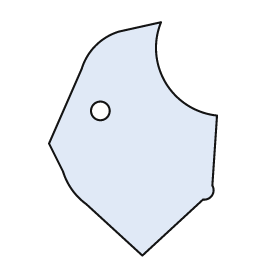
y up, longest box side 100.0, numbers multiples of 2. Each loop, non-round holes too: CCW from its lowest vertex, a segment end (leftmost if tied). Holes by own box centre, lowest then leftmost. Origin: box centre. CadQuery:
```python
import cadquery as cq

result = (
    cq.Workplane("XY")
    .moveTo(4.0, -50.0)
    .lineTo(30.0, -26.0)
    .threePointArc((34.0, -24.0), (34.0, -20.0))
    .lineTo(36.0, 10.0)
    .threePointArc((14.0, 24.0), (12.0, 50.0))
    .lineTo(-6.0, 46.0)
    .threePointArc((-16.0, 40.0), (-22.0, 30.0))
    .lineTo(-36.0, -2.0)
    .lineTo(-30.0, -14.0)
    .threePointArc((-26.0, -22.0), (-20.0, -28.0))
    .close()
    .moveTo(-14.0, 12.0)
    .circle(4.0)
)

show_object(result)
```